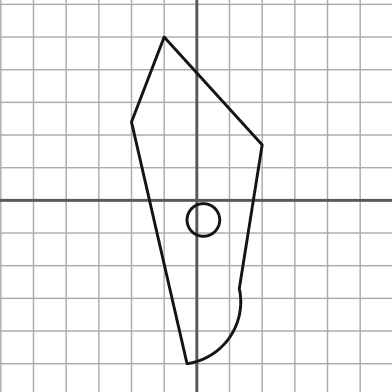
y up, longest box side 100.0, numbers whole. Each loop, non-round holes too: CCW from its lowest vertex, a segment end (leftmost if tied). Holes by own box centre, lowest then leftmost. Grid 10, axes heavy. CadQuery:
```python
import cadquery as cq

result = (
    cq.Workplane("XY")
    .moveTo(-3.0, -50.0)
    .threePointArc((10.0, -42.0), (13.0, -27.0))
    .lineTo(20.0, 17.0)
    .lineTo(-10.0, 50.0)
    .lineTo(-20.0, 24.0)
    .close()
    .moveTo(2.0, -6.0)
    .circle(5.0)
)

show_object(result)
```